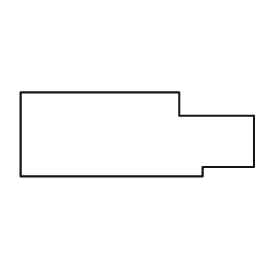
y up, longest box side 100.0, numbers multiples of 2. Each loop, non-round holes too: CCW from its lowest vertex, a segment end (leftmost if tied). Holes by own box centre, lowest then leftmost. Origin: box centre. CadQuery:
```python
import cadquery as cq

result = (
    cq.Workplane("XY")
    .moveTo(-50.0, -18.0)
    .lineTo(28.0, -18.0)
    .lineTo(28.0, -14.0)
    .lineTo(50.0, -14.0)
    .lineTo(50.0, 8.0)
    .lineTo(18.0, 8.0)
    .lineTo(18.0, 18.0)
    .lineTo(-50.0, 18.0)
    .close()
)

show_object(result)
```